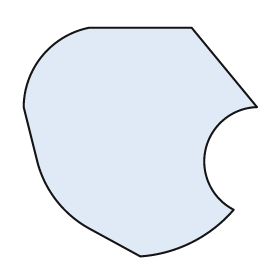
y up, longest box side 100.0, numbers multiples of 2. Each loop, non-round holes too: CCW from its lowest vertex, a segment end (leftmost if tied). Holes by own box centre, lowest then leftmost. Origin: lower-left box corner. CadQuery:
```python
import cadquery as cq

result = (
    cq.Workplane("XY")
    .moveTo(50.0, 0.0)
    .threePointArc((72.0, 6.0), (90.0, 20.0))
    .threePointArc((78.0, 46.0), (100.0, 64.0))
    .lineTo(72.0, 98.0)
    .lineTo(28.0, 98.0)
    .threePointArc((8.0, 86.0), (0.0, 64.0))
    .lineTo(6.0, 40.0)
    .threePointArc((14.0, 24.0), (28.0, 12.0))
    .close()
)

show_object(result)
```